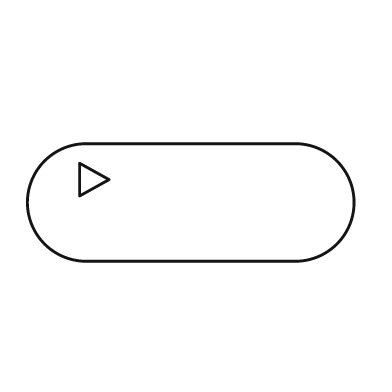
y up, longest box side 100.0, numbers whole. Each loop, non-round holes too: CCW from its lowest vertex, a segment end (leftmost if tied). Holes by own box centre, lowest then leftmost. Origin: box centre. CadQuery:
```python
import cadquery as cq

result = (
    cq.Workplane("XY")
    .moveTo(-32.0, -18.0)
    .lineTo(32.0, -18.0)
    .threePointArc((50.0, 0.0), (32.0, 18.0))
    .lineTo(-32.0, 18.0)
    .threePointArc((-50.0, 0.0), (-32.0, -18.0))
    .close()
    .moveTo(-34.0, 2.0)
    .lineTo(-25.0, 7.0)
    .lineTo(-34.0, 12.0)
    .close()
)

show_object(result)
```